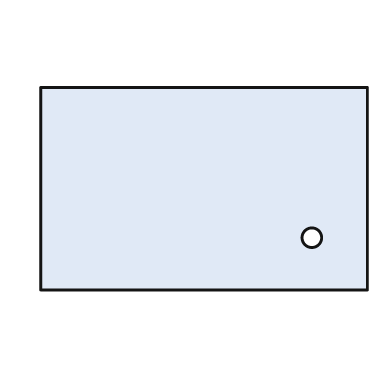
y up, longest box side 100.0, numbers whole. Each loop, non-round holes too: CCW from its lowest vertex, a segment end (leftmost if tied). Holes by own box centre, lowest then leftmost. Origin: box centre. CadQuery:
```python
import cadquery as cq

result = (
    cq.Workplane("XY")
    .moveTo(-50.0, -31.0)
    .lineTo(50.0, -31.0)
    .lineTo(50.0, 31.0)
    .lineTo(-50.0, 31.0)
    .close()
    .moveTo(33.0, -15.0)
    .circle(3.0)
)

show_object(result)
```